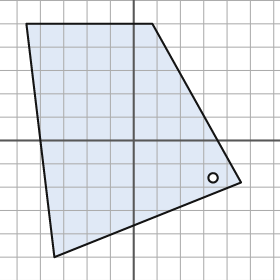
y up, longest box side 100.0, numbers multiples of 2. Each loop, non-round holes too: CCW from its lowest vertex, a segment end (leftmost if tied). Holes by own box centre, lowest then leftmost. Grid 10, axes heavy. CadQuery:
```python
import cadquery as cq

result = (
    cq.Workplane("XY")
    .moveTo(-34.0, -50.0)
    .lineTo(46.0, -18.0)
    .lineTo(8.0, 50.0)
    .lineTo(-46.0, 50.0)
    .close()
    .moveTo(34.0, -16.0)
    .circle(2.0)
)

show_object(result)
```